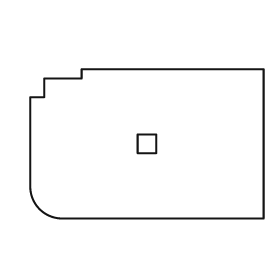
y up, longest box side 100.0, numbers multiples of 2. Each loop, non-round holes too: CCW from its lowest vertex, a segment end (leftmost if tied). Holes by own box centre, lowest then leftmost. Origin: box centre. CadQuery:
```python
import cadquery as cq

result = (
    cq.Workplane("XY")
    .moveTo(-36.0, -32.0)
    .lineTo(50.0, -32.0)
    .lineTo(50.0, 32.0)
    .lineTo(-28.0, 32.0)
    .lineTo(-28.0, 28.0)
    .lineTo(-44.0, 28.0)
    .lineTo(-44.0, 20.0)
    .lineTo(-50.0, 20.0)
    .lineTo(-50.0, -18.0)
    .threePointArc((-46.0, -28.0), (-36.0, -32.0))
    .close()
    .moveTo(-4.0, -4.0)
    .lineTo(4.0, -4.0)
    .lineTo(4.0, 4.0)
    .lineTo(-4.0, 4.0)
    .close()
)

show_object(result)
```